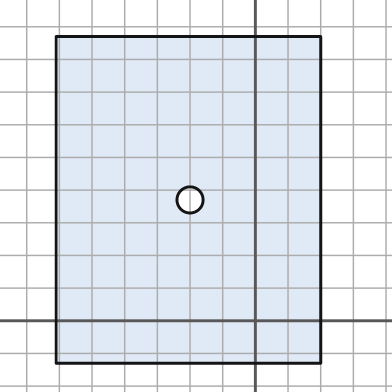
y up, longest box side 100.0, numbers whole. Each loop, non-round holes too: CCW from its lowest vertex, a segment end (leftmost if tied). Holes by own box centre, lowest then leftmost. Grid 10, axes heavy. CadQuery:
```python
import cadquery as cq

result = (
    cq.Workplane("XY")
    .moveTo(-61.0, -13.0)
    .lineTo(20.0, -13.0)
    .lineTo(20.0, 87.0)
    .lineTo(-61.0, 87.0)
    .close()
    .moveTo(-20.0, 37.0)
    .circle(4.0)
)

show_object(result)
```